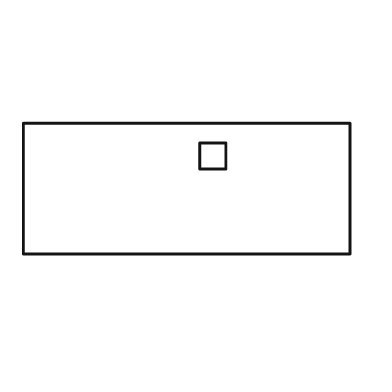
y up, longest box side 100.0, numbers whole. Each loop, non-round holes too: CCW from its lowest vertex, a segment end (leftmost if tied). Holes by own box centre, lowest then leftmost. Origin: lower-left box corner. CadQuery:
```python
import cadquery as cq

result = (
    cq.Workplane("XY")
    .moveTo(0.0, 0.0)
    .lineTo(100.0, 0.0)
    .lineTo(100.0, 40.0)
    .lineTo(0.0, 40.0)
    .close()
    .moveTo(54.0, 26.0)
    .lineTo(62.0, 26.0)
    .lineTo(62.0, 34.0)
    .lineTo(54.0, 34.0)
    .close()
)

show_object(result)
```